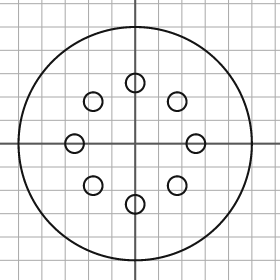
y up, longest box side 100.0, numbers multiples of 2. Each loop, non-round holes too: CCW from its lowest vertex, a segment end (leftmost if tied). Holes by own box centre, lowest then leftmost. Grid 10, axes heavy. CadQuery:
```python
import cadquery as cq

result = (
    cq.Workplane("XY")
    .moveTo(0.0, 0.0)
    .circle(50.0)
    .moveTo(0.0, -26.0)
    .circle(4.0)
    .moveTo(-18.0, -18.0)
    .circle(4.0)
    .moveTo(18.0, -18.0)
    .circle(4.0)
    .moveTo(-26.0, 0.0)
    .circle(4.0)
    .moveTo(26.0, 0.0)
    .circle(4.0)
    .moveTo(-18.0, 18.0)
    .circle(4.0)
    .moveTo(18.0, 18.0)
    .circle(4.0)
    .moveTo(0.0, 26.0)
    .circle(4.0)
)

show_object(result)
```